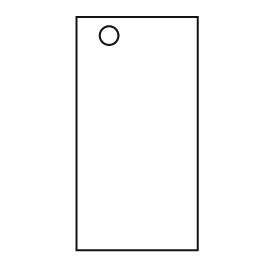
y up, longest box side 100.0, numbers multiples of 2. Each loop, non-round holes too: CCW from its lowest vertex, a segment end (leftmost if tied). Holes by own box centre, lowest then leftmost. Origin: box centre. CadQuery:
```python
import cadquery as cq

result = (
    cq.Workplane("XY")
    .moveTo(-26.0, -50.0)
    .lineTo(26.0, -50.0)
    .lineTo(26.0, 50.0)
    .lineTo(-26.0, 50.0)
    .close()
    .moveTo(-12.0, 42.0)
    .circle(4.0)
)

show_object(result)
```